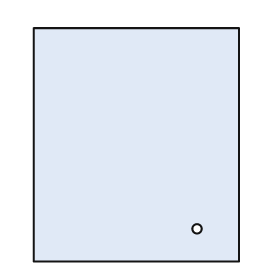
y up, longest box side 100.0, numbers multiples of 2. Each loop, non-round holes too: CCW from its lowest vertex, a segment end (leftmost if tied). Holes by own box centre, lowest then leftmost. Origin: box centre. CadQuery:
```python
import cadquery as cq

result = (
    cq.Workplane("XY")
    .moveTo(-44.0, -50.0)
    .lineTo(44.0, -50.0)
    .lineTo(44.0, 50.0)
    .lineTo(-44.0, 50.0)
    .close()
    .moveTo(26.0, -36.0)
    .circle(2.0)
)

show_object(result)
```